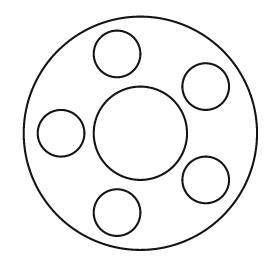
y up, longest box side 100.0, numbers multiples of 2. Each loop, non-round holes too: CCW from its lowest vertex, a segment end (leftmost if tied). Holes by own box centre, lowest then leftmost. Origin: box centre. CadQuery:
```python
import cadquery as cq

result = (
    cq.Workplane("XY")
    .moveTo(0.0, 0.0)
    .circle(50.0)
    .moveTo(-10.0, -34.0)
    .circle(10.0)
    .moveTo(28.0, -20.0)
    .circle(10.0)
    .moveTo(-34.0, 0.0)
    .circle(10.0)
    .moveTo(0.0, 0.0)
    .circle(20.0)
    .moveTo(28.0, 20.0)
    .circle(10.0)
    .moveTo(-10.0, 34.0)
    .circle(10.0)
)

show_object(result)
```